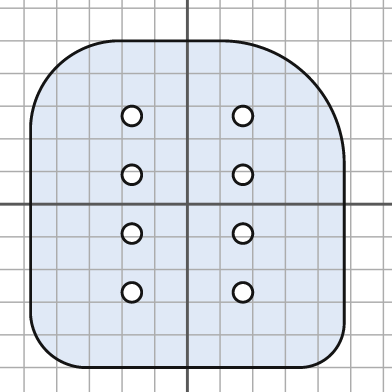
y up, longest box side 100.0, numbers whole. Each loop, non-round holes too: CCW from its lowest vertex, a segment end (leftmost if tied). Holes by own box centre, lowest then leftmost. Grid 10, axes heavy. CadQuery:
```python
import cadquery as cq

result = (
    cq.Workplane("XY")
    .moveTo(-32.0, -50.0)
    .lineTo(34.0, -50.0)
    .threePointArc((44.0, -46.0), (48.0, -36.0))
    .lineTo(48.0, 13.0)
    .threePointArc((37.0, 39.0), (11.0, 50.0))
    .lineTo(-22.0, 50.0)
    .threePointArc((-40.0, 42.0), (-48.0, 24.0))
    .lineTo(-48.0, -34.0)
    .threePointArc((-43.0, -45.0), (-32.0, -50.0))
    .close()
    .moveTo(-17.0, -27.0)
    .circle(3.0)
    .moveTo(17.0, -27.0)
    .circle(3.0)
    .moveTo(-17.0, -9.0)
    .circle(3.0)
    .moveTo(17.0, -9.0)
    .circle(3.0)
    .moveTo(-17.0, 9.0)
    .circle(3.0)
    .moveTo(17.0, 9.0)
    .circle(3.0)
    .moveTo(-17.0, 27.0)
    .circle(3.0)
    .moveTo(17.0, 27.0)
    .circle(3.0)
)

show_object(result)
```